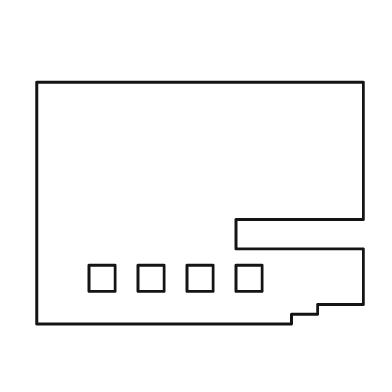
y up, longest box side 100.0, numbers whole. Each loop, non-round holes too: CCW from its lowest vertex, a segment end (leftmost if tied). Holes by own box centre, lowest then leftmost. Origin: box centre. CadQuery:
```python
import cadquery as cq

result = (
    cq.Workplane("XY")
    .moveTo(-50.0, -37.0)
    .lineTo(28.0, -37.0)
    .lineTo(28.0, -34.0)
    .lineTo(36.0, -34.0)
    .lineTo(36.0, -31.0)
    .lineTo(50.0, -31.0)
    .lineTo(50.0, -14.0)
    .lineTo(11.0, -14.0)
    .lineTo(11.0, -5.0)
    .lineTo(50.0, -5.0)
    .lineTo(50.0, 37.0)
    .lineTo(-50.0, 37.0)
    .close()
    .moveTo(-34.0, -27.0)
    .lineTo(-26.0, -27.0)
    .lineTo(-26.0, -19.0)
    .lineTo(-34.0, -19.0)
    .close()
    .moveTo(-19.0, -27.0)
    .lineTo(-11.0, -27.0)
    .lineTo(-11.0, -19.0)
    .lineTo(-19.0, -19.0)
    .close()
    .moveTo(-4.0, -27.0)
    .lineTo(4.0, -27.0)
    .lineTo(4.0, -19.0)
    .lineTo(-4.0, -19.0)
    .close()
    .moveTo(11.0, -27.0)
    .lineTo(19.0, -27.0)
    .lineTo(19.0, -19.0)
    .lineTo(11.0, -19.0)
    .close()
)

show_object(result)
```